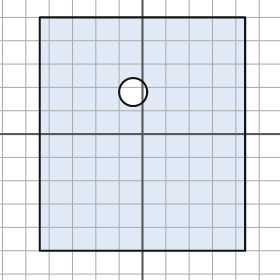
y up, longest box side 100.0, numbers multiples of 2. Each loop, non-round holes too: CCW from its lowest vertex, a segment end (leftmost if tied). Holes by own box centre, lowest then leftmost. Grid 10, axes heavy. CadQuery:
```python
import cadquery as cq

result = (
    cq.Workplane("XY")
    .moveTo(-44.0, -50.0)
    .lineTo(44.0, -50.0)
    .lineTo(44.0, 50.0)
    .lineTo(-44.0, 50.0)
    .close()
    .moveTo(-4.0, 18.0)
    .circle(6.0)
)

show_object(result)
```